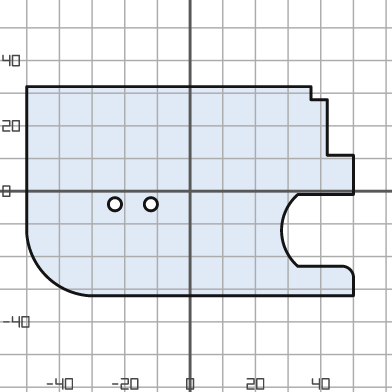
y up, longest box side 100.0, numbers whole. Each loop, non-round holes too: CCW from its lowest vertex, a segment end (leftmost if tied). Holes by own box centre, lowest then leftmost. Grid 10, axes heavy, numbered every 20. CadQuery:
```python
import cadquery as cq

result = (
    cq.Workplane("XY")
    .moveTo(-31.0, -32.0)
    .lineTo(50.0, -32.0)
    .lineTo(50.0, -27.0)
    .threePointArc((49.0, -24.0), (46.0, -23.0))
    .lineTo(33.0, -23.0)
    .threePointArc((28.0, -12.0), (33.0, -1.0))
    .lineTo(50.0, -1.0)
    .lineTo(50.0, 11.0)
    .lineTo(42.0, 11.0)
    .lineTo(42.0, 28.0)
    .lineTo(37.0, 28.0)
    .lineTo(37.0, 32.0)
    .lineTo(-50.0, 32.0)
    .lineTo(-50.0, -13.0)
    .threePointArc((-44.0, -26.0), (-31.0, -32.0))
    .close()
    .moveTo(-23.0, -4.0)
    .circle(2.0)
    .moveTo(-12.0, -4.0)
    .circle(2.0)
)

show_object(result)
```